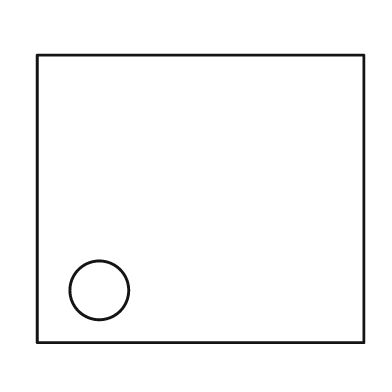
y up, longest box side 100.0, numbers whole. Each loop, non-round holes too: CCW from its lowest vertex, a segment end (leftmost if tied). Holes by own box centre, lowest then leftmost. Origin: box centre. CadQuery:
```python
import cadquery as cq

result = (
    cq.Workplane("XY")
    .moveTo(-50.0, -44.0)
    .lineTo(50.0, -44.0)
    .lineTo(50.0, 44.0)
    .lineTo(-50.0, 44.0)
    .close()
    .moveTo(-31.0, -28.0)
    .circle(9.0)
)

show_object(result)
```